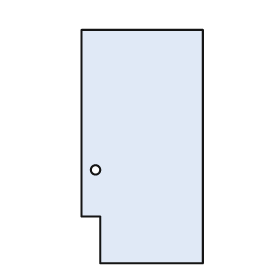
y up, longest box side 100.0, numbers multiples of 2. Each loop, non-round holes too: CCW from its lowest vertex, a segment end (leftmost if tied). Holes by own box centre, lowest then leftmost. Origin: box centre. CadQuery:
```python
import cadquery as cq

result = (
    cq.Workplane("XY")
    .moveTo(-18.0, -50.0)
    .lineTo(26.0, -50.0)
    .lineTo(26.0, 50.0)
    .lineTo(-26.0, 50.0)
    .lineTo(-26.0, -30.0)
    .lineTo(-18.0, -30.0)
    .close()
    .moveTo(-20.0, -10.0)
    .circle(2.0)
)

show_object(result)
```